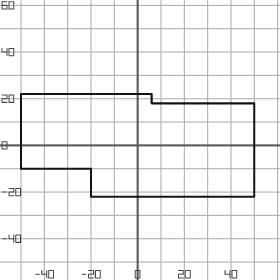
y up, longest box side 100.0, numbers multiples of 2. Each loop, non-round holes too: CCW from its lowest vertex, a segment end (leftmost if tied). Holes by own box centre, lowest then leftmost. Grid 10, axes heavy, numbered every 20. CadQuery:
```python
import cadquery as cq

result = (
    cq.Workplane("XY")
    .moveTo(-20.0, -22.0)
    .lineTo(50.0, -22.0)
    .lineTo(50.0, 18.0)
    .lineTo(6.0, 18.0)
    .lineTo(6.0, 22.0)
    .lineTo(-50.0, 22.0)
    .lineTo(-50.0, -10.0)
    .lineTo(-20.0, -10.0)
    .close()
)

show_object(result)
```